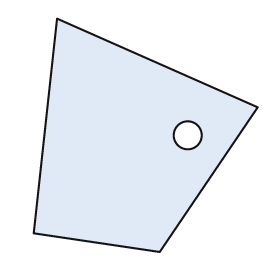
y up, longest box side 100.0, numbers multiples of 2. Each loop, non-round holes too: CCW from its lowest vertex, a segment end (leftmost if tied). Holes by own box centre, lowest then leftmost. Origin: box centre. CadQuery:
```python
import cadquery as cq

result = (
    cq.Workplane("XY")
    .moveTo(6.0, -50.0)
    .lineTo(48.0, 12.0)
    .lineTo(-38.0, 50.0)
    .lineTo(-48.0, -42.0)
    .close()
    .moveTo(18.0, 0.0)
    .circle(6.0)
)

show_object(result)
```